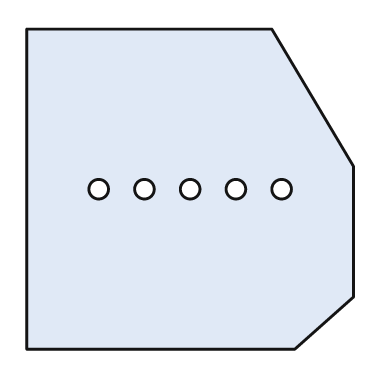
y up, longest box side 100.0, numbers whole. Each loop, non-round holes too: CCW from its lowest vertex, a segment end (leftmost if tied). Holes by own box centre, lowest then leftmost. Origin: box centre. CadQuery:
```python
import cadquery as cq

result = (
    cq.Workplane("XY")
    .moveTo(-50.0, -49.0)
    .lineTo(32.0, -49.0)
    .lineTo(50.0, -33.0)
    .lineTo(50.0, 7.0)
    .lineTo(25.0, 49.0)
    .lineTo(-50.0, 49.0)
    .close()
    .moveTo(-28.0, 0.0)
    .circle(3.0)
    .moveTo(-14.0, 0.0)
    .circle(3.0)
    .moveTo(0.0, 0.0)
    .circle(3.0)
    .moveTo(14.0, 0.0)
    .circle(3.0)
    .moveTo(28.0, 0.0)
    .circle(3.0)
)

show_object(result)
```